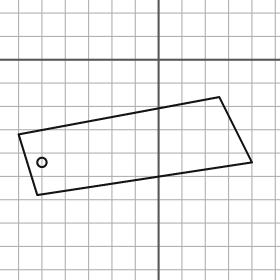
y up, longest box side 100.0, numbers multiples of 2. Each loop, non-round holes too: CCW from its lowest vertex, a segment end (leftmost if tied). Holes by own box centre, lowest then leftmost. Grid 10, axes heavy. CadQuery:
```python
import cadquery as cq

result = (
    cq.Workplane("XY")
    .moveTo(-52.0, -58.0)
    .lineTo(40.0, -44.0)
    .lineTo(26.0, -16.0)
    .lineTo(-60.0, -32.0)
    .close()
    .moveTo(-50.0, -44.0)
    .circle(2.0)
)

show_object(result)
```